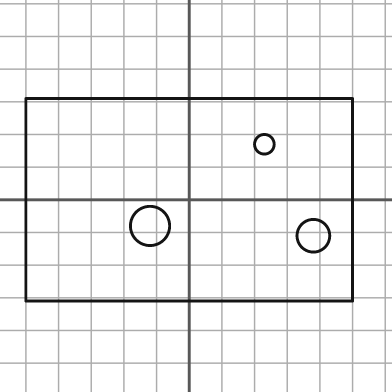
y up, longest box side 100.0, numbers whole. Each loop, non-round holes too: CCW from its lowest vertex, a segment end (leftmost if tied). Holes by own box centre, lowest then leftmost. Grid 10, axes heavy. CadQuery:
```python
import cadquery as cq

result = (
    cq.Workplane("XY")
    .moveTo(-50.0, -31.0)
    .lineTo(50.0, -31.0)
    .lineTo(50.0, 31.0)
    .lineTo(-50.0, 31.0)
    .close()
    .moveTo(38.0, -11.0)
    .circle(5.0)
    .moveTo(-12.0, -8.0)
    .circle(6.0)
    .moveTo(23.0, 17.0)
    .circle(3.0)
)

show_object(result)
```